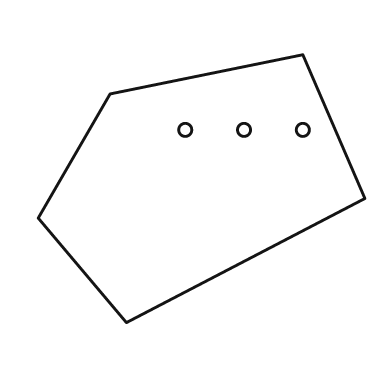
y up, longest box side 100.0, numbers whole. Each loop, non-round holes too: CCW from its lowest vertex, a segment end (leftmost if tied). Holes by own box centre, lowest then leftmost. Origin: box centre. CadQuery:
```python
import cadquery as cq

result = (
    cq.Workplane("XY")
    .moveTo(-23.0, -41.0)
    .lineTo(50.0, -3.0)
    .lineTo(31.0, 41.0)
    .lineTo(-28.0, 29.0)
    .lineTo(-50.0, -9.0)
    .close()
    .moveTo(-5.0, 18.0)
    .circle(2.0)
    .moveTo(13.0, 18.0)
    .circle(2.0)
    .moveTo(31.0, 18.0)
    .circle(2.0)
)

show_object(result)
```